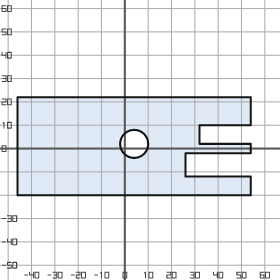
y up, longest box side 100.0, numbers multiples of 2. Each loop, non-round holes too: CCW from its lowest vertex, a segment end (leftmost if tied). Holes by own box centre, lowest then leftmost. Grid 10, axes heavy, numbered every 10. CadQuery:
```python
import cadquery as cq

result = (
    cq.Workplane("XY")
    .moveTo(-46.0, -20.0)
    .lineTo(54.0, -20.0)
    .lineTo(54.0, -12.0)
    .lineTo(26.0, -12.0)
    .lineTo(26.0, -2.0)
    .lineTo(54.0, -2.0)
    .lineTo(54.0, 2.0)
    .lineTo(32.0, 2.0)
    .lineTo(32.0, 10.0)
    .lineTo(54.0, 10.0)
    .lineTo(54.0, 22.0)
    .lineTo(-46.0, 22.0)
    .close()
    .moveTo(4.0, 2.0)
    .circle(6.0)
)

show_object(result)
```